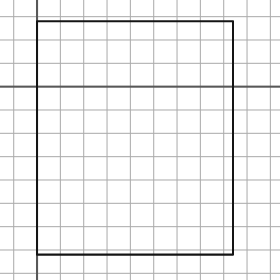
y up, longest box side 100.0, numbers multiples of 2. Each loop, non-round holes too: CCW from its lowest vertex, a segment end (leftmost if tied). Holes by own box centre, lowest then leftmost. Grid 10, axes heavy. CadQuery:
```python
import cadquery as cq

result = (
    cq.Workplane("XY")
    .moveTo(0.0, -72.0)
    .lineTo(84.0, -72.0)
    .lineTo(84.0, 28.0)
    .lineTo(0.0, 28.0)
    .close()
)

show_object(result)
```